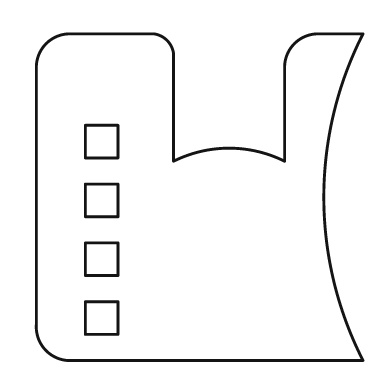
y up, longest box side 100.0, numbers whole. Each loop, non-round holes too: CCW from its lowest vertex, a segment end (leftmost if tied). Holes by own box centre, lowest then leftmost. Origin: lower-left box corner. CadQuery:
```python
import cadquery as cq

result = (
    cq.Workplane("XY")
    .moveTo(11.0, 0.0)
    .lineTo(100.0, 0.0)
    .threePointArc((88.0, 50.0), (100.0, 100.0))
    .lineTo(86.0, 100.0)
    .threePointArc((79.0, 97.0), (76.0, 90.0))
    .lineTo(76.0, 61.0)
    .threePointArc((59.0, 65.0), (42.0, 61.0))
    .lineTo(42.0, 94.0)
    .threePointArc((40.0, 98.0), (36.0, 100.0))
    .lineTo(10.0, 100.0)
    .threePointArc((3.0, 97.0), (0.0, 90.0))
    .lineTo(0.0, 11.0)
    .threePointArc((3.0, 3.0), (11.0, 0.0))
    .close()
    .moveTo(15.0, 8.0)
    .lineTo(25.0, 8.0)
    .lineTo(25.0, 18.0)
    .lineTo(15.0, 18.0)
    .close()
    .moveTo(15.0, 26.0)
    .lineTo(25.0, 26.0)
    .lineTo(25.0, 36.0)
    .lineTo(15.0, 36.0)
    .close()
    .moveTo(15.0, 44.0)
    .lineTo(25.0, 44.0)
    .lineTo(25.0, 54.0)
    .lineTo(15.0, 54.0)
    .close()
    .moveTo(15.0, 62.0)
    .lineTo(25.0, 62.0)
    .lineTo(25.0, 72.0)
    .lineTo(15.0, 72.0)
    .close()
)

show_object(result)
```